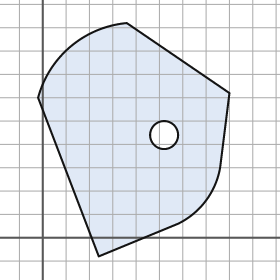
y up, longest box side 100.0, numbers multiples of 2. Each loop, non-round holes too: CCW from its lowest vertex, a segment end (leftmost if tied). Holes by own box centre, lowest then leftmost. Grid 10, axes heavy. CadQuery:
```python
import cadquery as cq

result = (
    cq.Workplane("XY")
    .moveTo(24.0, -8.0)
    .lineTo(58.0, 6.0)
    .threePointArc((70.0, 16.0), (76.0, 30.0))
    .lineTo(80.0, 62.0)
    .lineTo(36.0, 92.0)
    .threePointArc((12.0, 82.0), (-2.0, 60.0))
    .close()
    .moveTo(52.0, 44.0)
    .circle(6.0)
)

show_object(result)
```